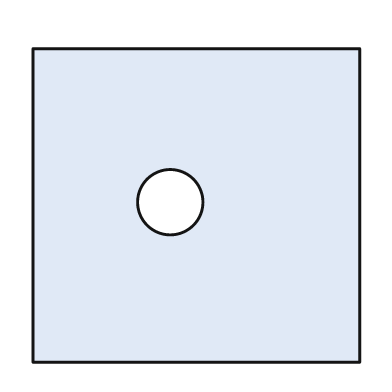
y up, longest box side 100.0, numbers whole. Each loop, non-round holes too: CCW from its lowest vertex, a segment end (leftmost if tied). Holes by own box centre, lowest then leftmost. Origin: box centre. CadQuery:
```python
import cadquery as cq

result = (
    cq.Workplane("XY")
    .moveTo(-50.0, -48.0)
    .lineTo(50.0, -48.0)
    .lineTo(50.0, 48.0)
    .lineTo(-50.0, 48.0)
    .close()
    .moveTo(-8.0, 1.0)
    .circle(10.0)
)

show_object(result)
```